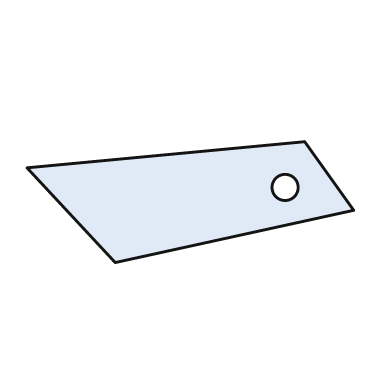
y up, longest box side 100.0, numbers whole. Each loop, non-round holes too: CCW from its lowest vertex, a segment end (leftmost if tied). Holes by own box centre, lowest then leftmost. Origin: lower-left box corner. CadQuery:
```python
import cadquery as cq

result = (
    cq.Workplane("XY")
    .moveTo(27.0, 0.0)
    .lineTo(100.0, 16.0)
    .lineTo(85.0, 37.0)
    .lineTo(0.0, 29.0)
    .close()
    .moveTo(79.0, 23.0)
    .circle(4.0)
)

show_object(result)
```